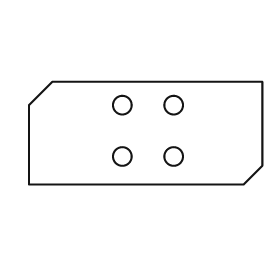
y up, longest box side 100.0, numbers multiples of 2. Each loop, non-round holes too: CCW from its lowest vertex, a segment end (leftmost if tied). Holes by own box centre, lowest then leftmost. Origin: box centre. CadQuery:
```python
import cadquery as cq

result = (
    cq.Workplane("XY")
    .moveTo(-50.0, -22.0)
    .lineTo(42.0, -22.0)
    .lineTo(50.0, -14.0)
    .lineTo(50.0, 22.0)
    .lineTo(-40.0, 22.0)
    .lineTo(-50.0, 12.0)
    .close()
    .moveTo(-10.0, -10.0)
    .circle(4.0)
    .moveTo(12.0, -10.0)
    .circle(4.0)
    .moveTo(-10.0, 12.0)
    .circle(4.0)
    .moveTo(12.0, 12.0)
    .circle(4.0)
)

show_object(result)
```